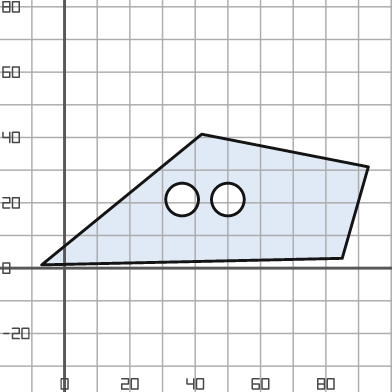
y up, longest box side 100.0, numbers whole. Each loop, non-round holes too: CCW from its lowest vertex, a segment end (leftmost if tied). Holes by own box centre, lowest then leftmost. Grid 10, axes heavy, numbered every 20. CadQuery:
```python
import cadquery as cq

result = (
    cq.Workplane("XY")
    .moveTo(-7.0, 1.0)
    .lineTo(85.0, 3.0)
    .lineTo(93.0, 31.0)
    .lineTo(42.0, 41.0)
    .close()
    .moveTo(36.0, 21.0)
    .circle(5.0)
    .moveTo(50.0, 21.0)
    .circle(5.0)
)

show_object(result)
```